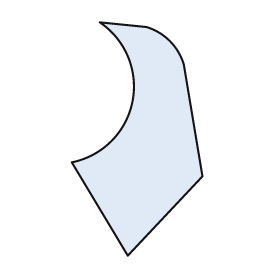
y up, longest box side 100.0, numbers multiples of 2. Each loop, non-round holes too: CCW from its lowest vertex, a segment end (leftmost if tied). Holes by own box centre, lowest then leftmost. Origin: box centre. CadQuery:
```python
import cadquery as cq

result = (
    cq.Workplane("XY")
    .moveTo(-4.0, -50.0)
    .lineTo(28.0, -16.0)
    .lineTo(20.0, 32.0)
    .threePointArc((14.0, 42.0), (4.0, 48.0))
    .lineTo(-16.0, 50.0)
    .threePointArc((-2.0, 16.0), (-28.0, -10.0))
    .close()
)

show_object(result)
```